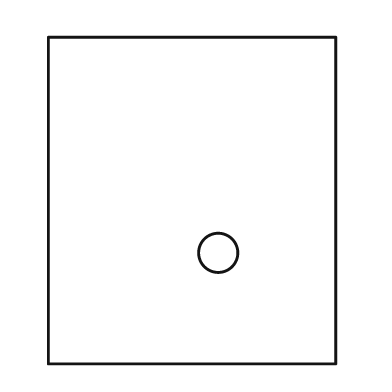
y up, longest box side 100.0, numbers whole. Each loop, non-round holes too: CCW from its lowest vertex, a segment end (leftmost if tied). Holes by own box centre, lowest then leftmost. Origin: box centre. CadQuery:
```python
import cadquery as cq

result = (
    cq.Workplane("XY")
    .moveTo(-44.0, -50.0)
    .lineTo(44.0, -50.0)
    .lineTo(44.0, 50.0)
    .lineTo(-44.0, 50.0)
    .close()
    .moveTo(8.0, -16.0)
    .circle(6.0)
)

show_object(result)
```